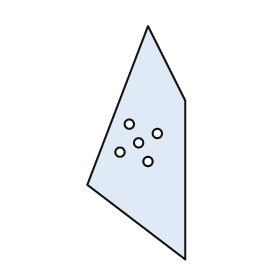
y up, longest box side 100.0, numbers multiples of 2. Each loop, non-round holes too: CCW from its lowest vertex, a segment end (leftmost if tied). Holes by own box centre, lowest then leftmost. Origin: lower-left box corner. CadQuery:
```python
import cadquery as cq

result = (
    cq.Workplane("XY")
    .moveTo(42.0, 0.0)
    .lineTo(42.0, 68.0)
    .lineTo(26.0, 100.0)
    .lineTo(0.0, 32.0)
    .close()
    .moveTo(26.0, 42.0)
    .circle(2.0)
    .moveTo(14.0, 46.0)
    .circle(2.0)
    .moveTo(22.0, 50.0)
    .circle(2.0)
    .moveTo(30.0, 54.0)
    .circle(2.0)
    .moveTo(18.0, 58.0)
    .circle(2.0)
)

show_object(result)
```